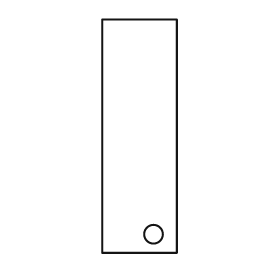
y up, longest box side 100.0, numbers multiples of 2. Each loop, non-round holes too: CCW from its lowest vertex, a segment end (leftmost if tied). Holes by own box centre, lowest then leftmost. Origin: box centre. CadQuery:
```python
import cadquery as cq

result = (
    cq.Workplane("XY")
    .moveTo(-16.0, -50.0)
    .lineTo(16.0, -50.0)
    .lineTo(16.0, 50.0)
    .lineTo(-16.0, 50.0)
    .close()
    .moveTo(6.0, -42.0)
    .circle(4.0)
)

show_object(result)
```